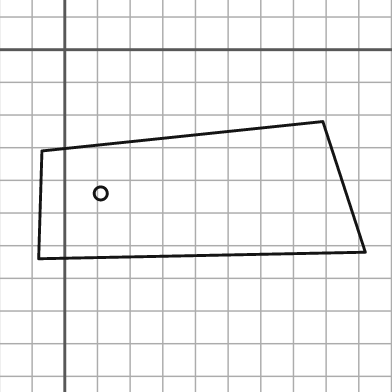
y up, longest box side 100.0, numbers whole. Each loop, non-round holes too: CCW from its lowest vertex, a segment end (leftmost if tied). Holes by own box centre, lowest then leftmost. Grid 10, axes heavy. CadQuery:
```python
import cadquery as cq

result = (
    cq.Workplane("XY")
    .moveTo(-8.0, -64.0)
    .lineTo(92.0, -62.0)
    .lineTo(79.0, -22.0)
    .lineTo(-7.0, -31.0)
    .close()
    .moveTo(11.0, -44.0)
    .circle(2.0)
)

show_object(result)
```